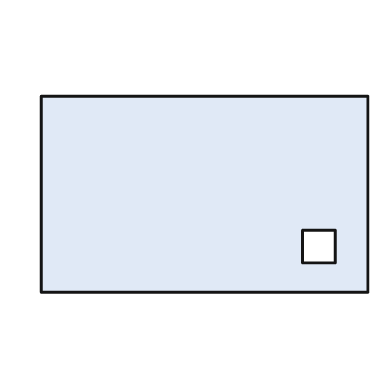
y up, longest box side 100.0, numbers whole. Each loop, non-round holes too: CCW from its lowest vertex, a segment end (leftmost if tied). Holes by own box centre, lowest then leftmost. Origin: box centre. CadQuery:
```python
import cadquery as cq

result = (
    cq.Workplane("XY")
    .moveTo(-50.0, -30.0)
    .lineTo(50.0, -30.0)
    .lineTo(50.0, 30.0)
    .lineTo(-50.0, 30.0)
    .close()
    .moveTo(30.0, -21.0)
    .lineTo(40.0, -21.0)
    .lineTo(40.0, -11.0)
    .lineTo(30.0, -11.0)
    .close()
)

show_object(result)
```